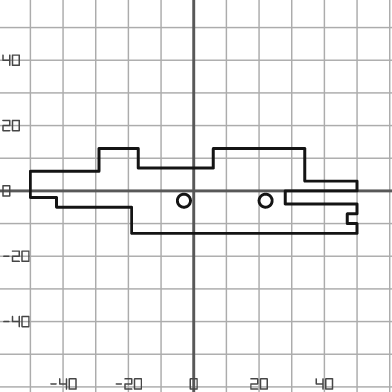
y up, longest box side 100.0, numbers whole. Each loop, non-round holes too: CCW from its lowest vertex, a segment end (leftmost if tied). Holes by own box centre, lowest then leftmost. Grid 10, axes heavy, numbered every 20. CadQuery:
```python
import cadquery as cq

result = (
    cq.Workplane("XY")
    .moveTo(-19.0, -13.0)
    .lineTo(50.0, -13.0)
    .lineTo(50.0, -10.0)
    .lineTo(47.0, -10.0)
    .lineTo(47.0, -7.0)
    .lineTo(50.0, -7.0)
    .lineTo(50.0, -4.0)
    .lineTo(28.0, -4.0)
    .lineTo(28.0, 0.0)
    .lineTo(50.0, 0.0)
    .lineTo(50.0, 3.0)
    .lineTo(34.0, 3.0)
    .lineTo(34.0, 13.0)
    .lineTo(6.0, 13.0)
    .lineTo(6.0, 7.0)
    .lineTo(-17.0, 7.0)
    .lineTo(-17.0, 13.0)
    .lineTo(-29.0, 13.0)
    .lineTo(-29.0, 6.0)
    .lineTo(-50.0, 6.0)
    .lineTo(-50.0, -2.0)
    .lineTo(-42.0, -2.0)
    .lineTo(-42.0, -5.0)
    .lineTo(-19.0, -5.0)
    .close()
    .moveTo(-3.0, -3.0)
    .circle(2.0)
    .moveTo(22.0, -3.0)
    .circle(2.0)
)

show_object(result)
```